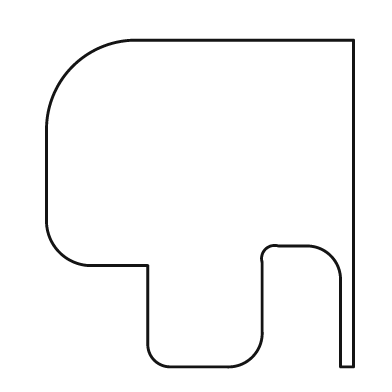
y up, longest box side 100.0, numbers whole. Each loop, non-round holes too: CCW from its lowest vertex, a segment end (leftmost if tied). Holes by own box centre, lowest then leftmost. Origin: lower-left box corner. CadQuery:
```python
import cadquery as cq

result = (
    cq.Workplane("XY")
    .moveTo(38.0, 0.0)
    .lineTo(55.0, 0.0)
    .threePointArc((63.0, 3.0), (66.0, 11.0))
    .lineTo(66.0, 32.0)
    .threePointArc((67.0, 36.0), (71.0, 37.0))
    .lineTo(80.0, 37.0)
    .threePointArc((87.0, 34.0), (90.0, 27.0))
    .lineTo(90.0, 0.0)
    .lineTo(94.0, 0.0)
    .lineTo(94.0, 100.0)
    .lineTo(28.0, 100.0)
    .threePointArc((8.0, 92.0), (0.0, 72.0))
    .lineTo(0.0, 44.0)
    .threePointArc((4.0, 35.0), (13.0, 31.0))
    .lineTo(31.0, 31.0)
    .lineTo(31.0, 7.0)
    .threePointArc((33.0, 2.0), (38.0, 0.0))
    .close()
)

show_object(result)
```